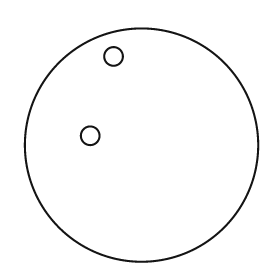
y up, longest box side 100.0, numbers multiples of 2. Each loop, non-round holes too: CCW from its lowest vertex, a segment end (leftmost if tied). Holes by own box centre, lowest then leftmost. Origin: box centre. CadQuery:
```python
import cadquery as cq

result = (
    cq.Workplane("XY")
    .moveTo(0.0, 0.0)
    .circle(50.0)
    .moveTo(-22.0, 4.0)
    .circle(4.0)
    .moveTo(-12.0, 38.0)
    .circle(4.0)
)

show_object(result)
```